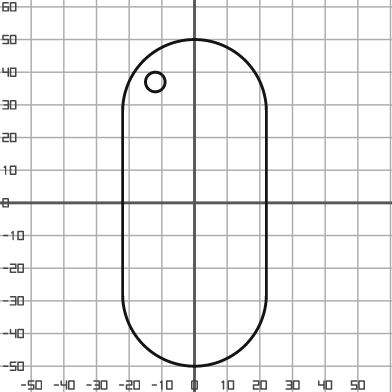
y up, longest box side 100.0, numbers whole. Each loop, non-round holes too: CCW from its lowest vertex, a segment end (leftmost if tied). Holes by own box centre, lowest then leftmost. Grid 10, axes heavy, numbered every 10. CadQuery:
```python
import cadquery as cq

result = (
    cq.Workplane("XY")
    .moveTo(-22.0, -28.0)
    .threePointArc((0.0, -50.0), (22.0, -28.0))
    .lineTo(22.0, 28.0)
    .threePointArc((0.0, 50.0), (-22.0, 28.0))
    .close()
    .moveTo(-12.0, 37.0)
    .circle(3.0)
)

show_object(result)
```